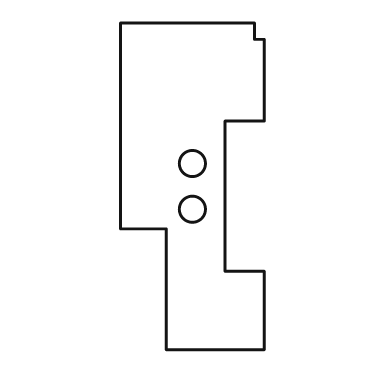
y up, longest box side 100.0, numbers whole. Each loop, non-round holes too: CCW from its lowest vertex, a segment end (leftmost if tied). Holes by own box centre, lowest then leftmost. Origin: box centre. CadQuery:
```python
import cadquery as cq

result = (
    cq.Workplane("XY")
    .moveTo(-8.0, -50.0)
    .lineTo(22.0, -50.0)
    .lineTo(22.0, -26.0)
    .lineTo(10.0, -26.0)
    .lineTo(10.0, 20.0)
    .lineTo(22.0, 20.0)
    .lineTo(22.0, 45.0)
    .lineTo(19.0, 45.0)
    .lineTo(19.0, 50.0)
    .lineTo(-22.0, 50.0)
    .lineTo(-22.0, -13.0)
    .lineTo(-8.0, -13.0)
    .close()
    .moveTo(0.0, -7.0)
    .circle(4.0)
    .moveTo(0.0, 7.0)
    .circle(4.0)
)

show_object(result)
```